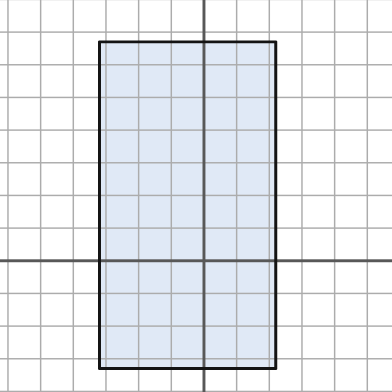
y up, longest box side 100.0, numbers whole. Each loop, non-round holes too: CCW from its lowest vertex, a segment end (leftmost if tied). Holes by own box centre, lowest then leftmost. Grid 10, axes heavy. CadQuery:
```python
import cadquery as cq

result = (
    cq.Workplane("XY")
    .moveTo(-32.0, -33.0)
    .lineTo(22.0, -33.0)
    .lineTo(22.0, 67.0)
    .lineTo(-32.0, 67.0)
    .close()
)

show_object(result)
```